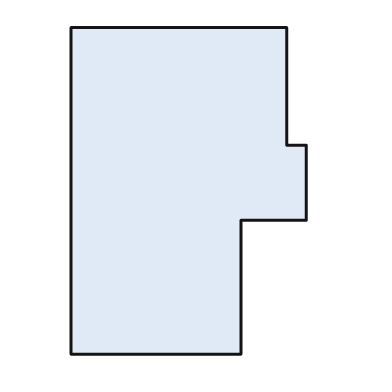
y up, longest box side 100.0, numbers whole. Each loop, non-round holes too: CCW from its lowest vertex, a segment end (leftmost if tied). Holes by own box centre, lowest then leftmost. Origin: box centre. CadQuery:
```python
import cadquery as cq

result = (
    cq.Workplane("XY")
    .moveTo(-36.0, -50.0)
    .lineTo(16.0, -50.0)
    .lineTo(16.0, -9.0)
    .lineTo(36.0, -9.0)
    .lineTo(36.0, 14.0)
    .lineTo(30.0, 14.0)
    .lineTo(30.0, 50.0)
    .lineTo(-36.0, 50.0)
    .close()
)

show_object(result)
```